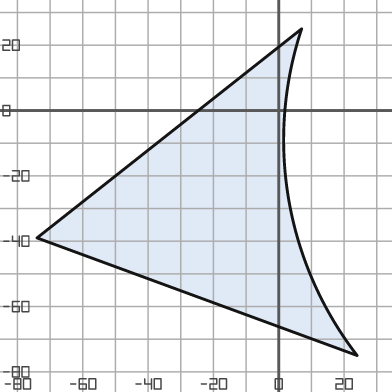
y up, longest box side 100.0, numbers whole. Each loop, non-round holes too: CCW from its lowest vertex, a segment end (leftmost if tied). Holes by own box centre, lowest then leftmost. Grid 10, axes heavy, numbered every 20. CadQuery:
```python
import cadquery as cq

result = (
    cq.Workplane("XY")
    .moveTo(24.0, -75.0)
    .threePointArc((3.0, -27.0), (7.0, 25.0))
    .lineTo(-74.0, -39.0)
    .close()
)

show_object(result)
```